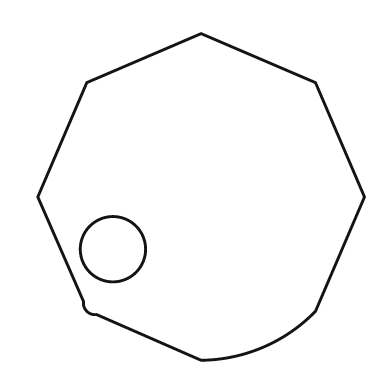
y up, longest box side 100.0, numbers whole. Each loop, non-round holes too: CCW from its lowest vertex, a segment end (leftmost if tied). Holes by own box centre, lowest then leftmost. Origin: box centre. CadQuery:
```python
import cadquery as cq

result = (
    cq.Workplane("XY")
    .moveTo(0.0, -50.0)
    .threePointArc((19.0, -46.0), (35.0, -35.0))
    .lineTo(50.0, 0.0)
    .lineTo(35.0, 35.0)
    .lineTo(0.0, 50.0)
    .lineTo(-35.0, 35.0)
    .lineTo(-50.0, 0.0)
    .lineTo(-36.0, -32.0)
    .threePointArc((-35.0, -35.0), (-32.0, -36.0))
    .close()
    .moveTo(-27.0, -16.0)
    .circle(10.0)
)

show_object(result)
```